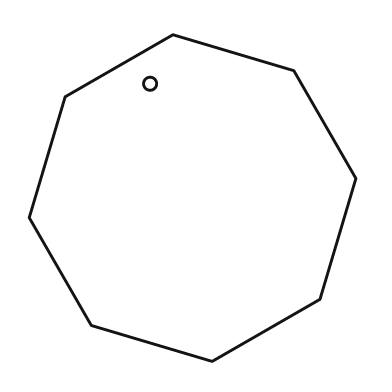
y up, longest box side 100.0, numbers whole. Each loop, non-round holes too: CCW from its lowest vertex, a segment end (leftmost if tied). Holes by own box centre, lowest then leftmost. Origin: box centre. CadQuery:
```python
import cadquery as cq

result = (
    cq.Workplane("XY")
    .moveTo(6.0, -50.0)
    .lineTo(39.0, -31.0)
    .lineTo(50.0, 6.0)
    .lineTo(31.0, 39.0)
    .lineTo(-6.0, 50.0)
    .lineTo(-39.0, 31.0)
    .lineTo(-50.0, -6.0)
    .lineTo(-31.0, -39.0)
    .close()
    .moveTo(-13.0, 35.0)
    .circle(2.0)
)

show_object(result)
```